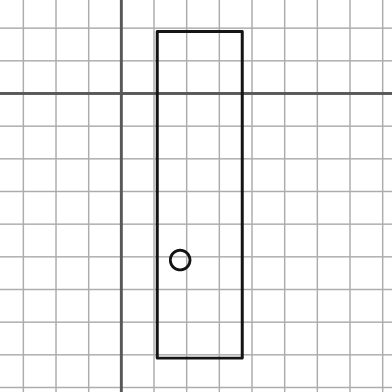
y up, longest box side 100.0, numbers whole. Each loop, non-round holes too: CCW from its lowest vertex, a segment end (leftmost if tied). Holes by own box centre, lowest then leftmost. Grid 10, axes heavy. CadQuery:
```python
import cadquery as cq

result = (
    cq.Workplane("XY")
    .moveTo(11.0, -81.0)
    .lineTo(37.0, -81.0)
    .lineTo(37.0, 19.0)
    .lineTo(11.0, 19.0)
    .close()
    .moveTo(18.0, -51.0)
    .circle(3.0)
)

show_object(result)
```